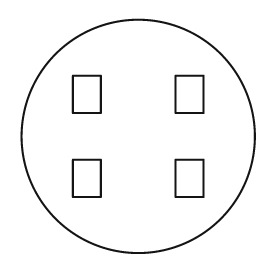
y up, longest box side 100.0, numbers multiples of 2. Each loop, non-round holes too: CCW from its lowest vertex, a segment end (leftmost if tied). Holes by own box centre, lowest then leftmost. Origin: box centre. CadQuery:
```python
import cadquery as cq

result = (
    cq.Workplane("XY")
    .moveTo(0.0, 0.0)
    .circle(50.0)
    .moveTo(-28.0, -26.0)
    .lineTo(-16.0, -26.0)
    .lineTo(-16.0, -10.0)
    .lineTo(-28.0, -10.0)
    .close()
    .moveTo(16.0, -26.0)
    .lineTo(28.0, -26.0)
    .lineTo(28.0, -10.0)
    .lineTo(16.0, -10.0)
    .close()
    .moveTo(-28.0, 10.0)
    .lineTo(-16.0, 10.0)
    .lineTo(-16.0, 26.0)
    .lineTo(-28.0, 26.0)
    .close()
    .moveTo(16.0, 10.0)
    .lineTo(28.0, 10.0)
    .lineTo(28.0, 26.0)
    .lineTo(16.0, 26.0)
    .close()
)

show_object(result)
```